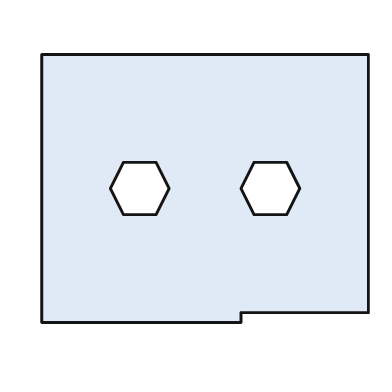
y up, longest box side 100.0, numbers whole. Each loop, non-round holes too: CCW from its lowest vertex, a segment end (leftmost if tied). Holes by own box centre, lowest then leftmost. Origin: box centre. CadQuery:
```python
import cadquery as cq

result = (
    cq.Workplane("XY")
    .moveTo(-50.0, -41.0)
    .lineTo(11.0, -41.0)
    .lineTo(11.0, -38.0)
    .lineTo(50.0, -38.0)
    .lineTo(50.0, 41.0)
    .lineTo(-50.0, 41.0)
    .close()
    .moveTo(-25.0, -8.0)
    .lineTo(-15.0, -8.0)
    .lineTo(-11.0, 0.0)
    .lineTo(-15.0, 8.0)
    .lineTo(-25.0, 8.0)
    .lineTo(-29.0, 0.0)
    .close()
    .moveTo(15.0, -8.0)
    .lineTo(25.0, -8.0)
    .lineTo(29.0, 0.0)
    .lineTo(25.0, 8.0)
    .lineTo(15.0, 8.0)
    .lineTo(11.0, 0.0)
    .close()
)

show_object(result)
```